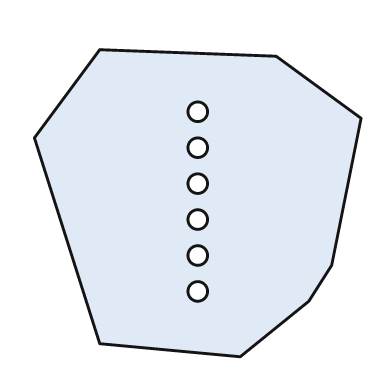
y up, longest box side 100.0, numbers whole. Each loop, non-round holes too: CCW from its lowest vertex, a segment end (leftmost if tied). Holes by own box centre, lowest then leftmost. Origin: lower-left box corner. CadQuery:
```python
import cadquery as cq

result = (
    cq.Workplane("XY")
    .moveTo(63.0, 0.0)
    .lineTo(84.0, 17.0)
    .lineTo(91.0, 28.0)
    .lineTo(100.0, 73.0)
    .lineTo(74.0, 92.0)
    .lineTo(20.0, 94.0)
    .lineTo(0.0, 67.0)
    .lineTo(20.0, 4.0)
    .close()
    .moveTo(50.0, 20.0)
    .circle(3.0)
    .moveTo(50.0, 31.0)
    .circle(3.0)
    .moveTo(50.0, 42.0)
    .circle(3.0)
    .moveTo(50.0, 53.0)
    .circle(3.0)
    .moveTo(50.0, 64.0)
    .circle(3.0)
    .moveTo(50.0, 75.0)
    .circle(3.0)
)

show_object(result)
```